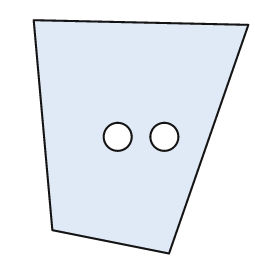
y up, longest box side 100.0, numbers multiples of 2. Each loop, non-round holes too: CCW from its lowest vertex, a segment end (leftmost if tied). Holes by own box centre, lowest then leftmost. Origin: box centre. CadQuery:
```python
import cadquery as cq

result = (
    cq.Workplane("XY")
    .moveTo(12.0, -50.0)
    .lineTo(46.0, 48.0)
    .lineTo(-46.0, 50.0)
    .lineTo(-38.0, -40.0)
    .close()
    .moveTo(-10.0, 0.0)
    .circle(6.0)
    .moveTo(10.0, 0.0)
    .circle(6.0)
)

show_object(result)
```